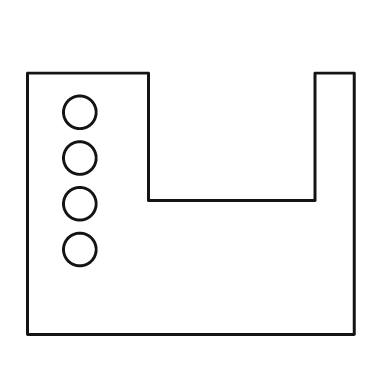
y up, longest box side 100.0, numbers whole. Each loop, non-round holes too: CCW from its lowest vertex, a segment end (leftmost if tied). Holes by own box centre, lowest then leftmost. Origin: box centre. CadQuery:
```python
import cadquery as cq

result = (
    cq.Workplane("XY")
    .moveTo(-50.0, -40.0)
    .lineTo(50.0, -40.0)
    .lineTo(50.0, 40.0)
    .lineTo(38.0, 40.0)
    .lineTo(38.0, 1.0)
    .lineTo(-13.0, 1.0)
    .lineTo(-13.0, 40.0)
    .lineTo(-50.0, 40.0)
    .close()
    .moveTo(-34.0, -14.0)
    .circle(5.0)
    .moveTo(-34.0, 0.0)
    .circle(5.0)
    .moveTo(-34.0, 14.0)
    .circle(5.0)
    .moveTo(-34.0, 28.0)
    .circle(5.0)
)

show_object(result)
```